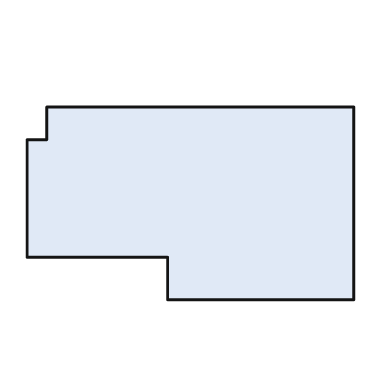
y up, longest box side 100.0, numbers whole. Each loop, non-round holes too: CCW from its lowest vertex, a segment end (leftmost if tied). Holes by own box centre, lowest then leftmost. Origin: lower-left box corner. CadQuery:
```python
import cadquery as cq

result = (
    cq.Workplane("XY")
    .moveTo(43.0, 0.0)
    .lineTo(100.0, 0.0)
    .lineTo(100.0, 59.0)
    .lineTo(6.0, 59.0)
    .lineTo(6.0, 49.0)
    .lineTo(0.0, 49.0)
    .lineTo(0.0, 13.0)
    .lineTo(43.0, 13.0)
    .close()
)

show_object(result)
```